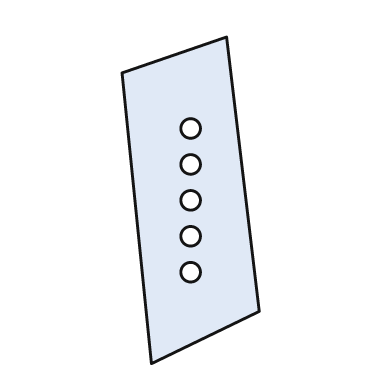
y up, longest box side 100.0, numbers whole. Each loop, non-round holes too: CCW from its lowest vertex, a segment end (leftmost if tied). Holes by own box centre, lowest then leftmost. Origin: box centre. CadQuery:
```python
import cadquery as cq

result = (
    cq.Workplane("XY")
    .moveTo(-12.0, -50.0)
    .lineTo(21.0, -34.0)
    .lineTo(11.0, 50.0)
    .lineTo(-21.0, 39.0)
    .close()
    .moveTo(0.0, -22.0)
    .circle(3.0)
    .moveTo(0.0, -11.0)
    .circle(3.0)
    .moveTo(0.0, 0.0)
    .circle(3.0)
    .moveTo(0.0, 11.0)
    .circle(3.0)
    .moveTo(0.0, 22.0)
    .circle(3.0)
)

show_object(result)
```